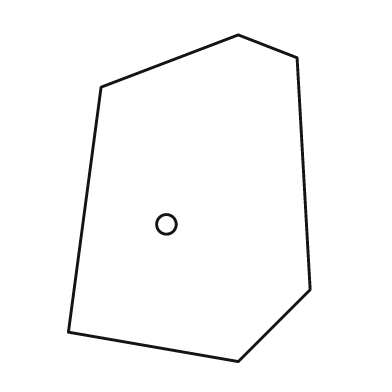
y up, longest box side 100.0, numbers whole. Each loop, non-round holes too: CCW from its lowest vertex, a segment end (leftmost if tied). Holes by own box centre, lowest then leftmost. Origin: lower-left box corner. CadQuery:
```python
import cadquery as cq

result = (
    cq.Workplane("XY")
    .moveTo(52.0, 0.0)
    .lineTo(74.0, 22.0)
    .lineTo(70.0, 93.0)
    .lineTo(52.0, 100.0)
    .lineTo(10.0, 84.0)
    .lineTo(0.0, 9.0)
    .close()
    .moveTo(30.0, 42.0)
    .circle(3.0)
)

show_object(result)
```